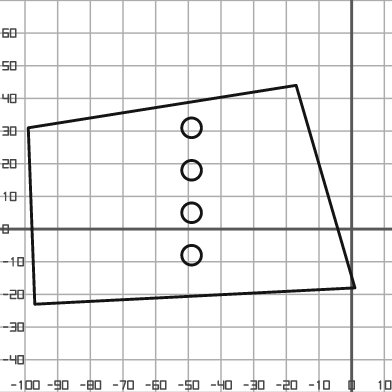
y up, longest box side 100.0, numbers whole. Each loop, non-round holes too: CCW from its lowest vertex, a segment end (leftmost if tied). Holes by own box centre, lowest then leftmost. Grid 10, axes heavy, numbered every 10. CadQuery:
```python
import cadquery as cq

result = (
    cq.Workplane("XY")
    .moveTo(-97.0, -23.0)
    .lineTo(1.0, -18.0)
    .lineTo(-17.0, 44.0)
    .lineTo(-99.0, 31.0)
    .close()
    .moveTo(-49.0, -8.0)
    .circle(3.0)
    .moveTo(-49.0, 5.0)
    .circle(3.0)
    .moveTo(-49.0, 18.0)
    .circle(3.0)
    .moveTo(-49.0, 31.0)
    .circle(3.0)
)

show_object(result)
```